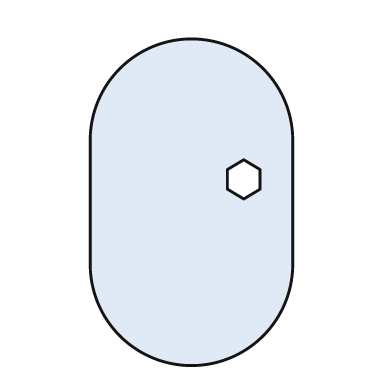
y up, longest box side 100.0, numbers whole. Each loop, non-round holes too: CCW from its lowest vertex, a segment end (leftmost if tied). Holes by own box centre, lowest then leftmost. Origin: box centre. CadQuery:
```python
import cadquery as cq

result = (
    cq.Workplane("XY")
    .moveTo(-31.0, -19.0)
    .threePointArc((0.0, -50.0), (31.0, -19.0))
    .lineTo(31.0, 19.0)
    .threePointArc((0.0, 50.0), (-31.0, 19.0))
    .close()
    .moveTo(16.0, 1.0)
    .lineTo(21.0, 4.0)
    .lineTo(21.0, 10.0)
    .lineTo(16.0, 13.0)
    .lineTo(11.0, 10.0)
    .lineTo(11.0, 4.0)
    .close()
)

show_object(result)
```